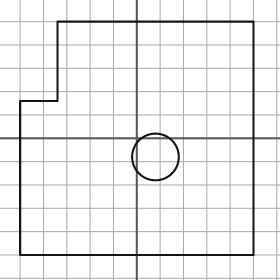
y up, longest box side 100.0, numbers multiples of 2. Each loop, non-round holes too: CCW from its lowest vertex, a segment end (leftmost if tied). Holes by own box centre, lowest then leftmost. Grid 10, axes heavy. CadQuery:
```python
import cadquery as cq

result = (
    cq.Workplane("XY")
    .moveTo(-50.0, -50.0)
    .lineTo(50.0, -50.0)
    .lineTo(50.0, 50.0)
    .lineTo(-34.0, 50.0)
    .lineTo(-34.0, 16.0)
    .lineTo(-50.0, 16.0)
    .close()
    .moveTo(8.0, -8.0)
    .circle(10.0)
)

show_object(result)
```